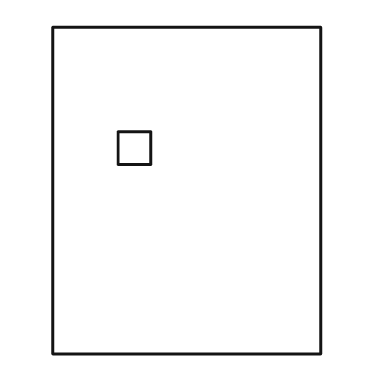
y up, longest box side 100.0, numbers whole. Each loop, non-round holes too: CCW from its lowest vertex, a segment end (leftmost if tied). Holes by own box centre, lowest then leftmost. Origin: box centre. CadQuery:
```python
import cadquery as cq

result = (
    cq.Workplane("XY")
    .moveTo(-41.0, -50.0)
    .lineTo(41.0, -50.0)
    .lineTo(41.0, 50.0)
    .lineTo(-41.0, 50.0)
    .close()
    .moveTo(-21.0, 8.0)
    .lineTo(-11.0, 8.0)
    .lineTo(-11.0, 18.0)
    .lineTo(-21.0, 18.0)
    .close()
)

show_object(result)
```